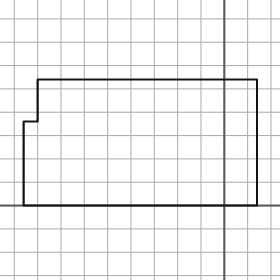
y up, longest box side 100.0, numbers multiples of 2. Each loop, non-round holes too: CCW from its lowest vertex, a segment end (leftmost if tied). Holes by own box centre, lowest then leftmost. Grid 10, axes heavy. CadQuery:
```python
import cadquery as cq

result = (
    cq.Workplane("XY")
    .moveTo(-86.0, 0.0)
    .lineTo(14.0, 0.0)
    .lineTo(14.0, 54.0)
    .lineTo(-80.0, 54.0)
    .lineTo(-80.0, 36.0)
    .lineTo(-86.0, 36.0)
    .close()
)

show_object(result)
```